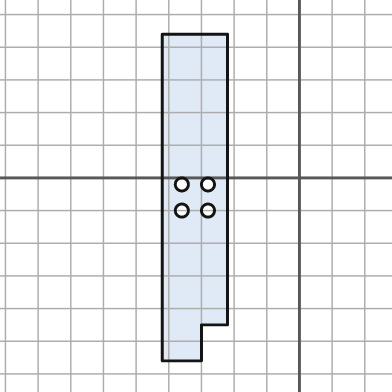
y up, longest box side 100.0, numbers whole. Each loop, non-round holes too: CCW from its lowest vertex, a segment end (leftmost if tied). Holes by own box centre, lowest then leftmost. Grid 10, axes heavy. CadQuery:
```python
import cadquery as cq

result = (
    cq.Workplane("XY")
    .moveTo(-42.0, -56.0)
    .lineTo(-30.0, -56.0)
    .lineTo(-30.0, -45.0)
    .lineTo(-22.0, -45.0)
    .lineTo(-22.0, 44.0)
    .lineTo(-42.0, 44.0)
    .close()
    .moveTo(-36.0, -10.0)
    .circle(2.0)
    .moveTo(-28.0, -10.0)
    .circle(2.0)
    .moveTo(-36.0, -2.0)
    .circle(2.0)
    .moveTo(-28.0, -2.0)
    .circle(2.0)
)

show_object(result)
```